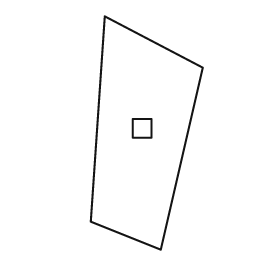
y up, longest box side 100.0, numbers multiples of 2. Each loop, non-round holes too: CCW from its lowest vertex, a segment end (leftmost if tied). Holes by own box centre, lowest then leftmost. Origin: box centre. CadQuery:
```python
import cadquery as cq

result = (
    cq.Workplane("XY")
    .moveTo(6.0, -50.0)
    .lineTo(24.0, 28.0)
    .lineTo(-18.0, 50.0)
    .lineTo(-24.0, -38.0)
    .close()
    .moveTo(-6.0, -2.0)
    .lineTo(2.0, -2.0)
    .lineTo(2.0, 6.0)
    .lineTo(-6.0, 6.0)
    .close()
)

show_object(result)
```